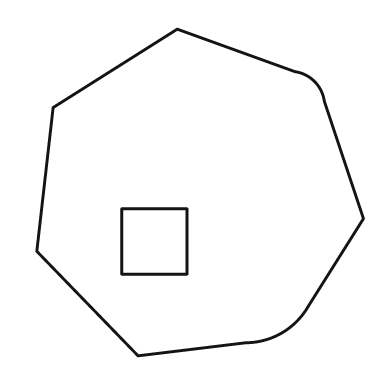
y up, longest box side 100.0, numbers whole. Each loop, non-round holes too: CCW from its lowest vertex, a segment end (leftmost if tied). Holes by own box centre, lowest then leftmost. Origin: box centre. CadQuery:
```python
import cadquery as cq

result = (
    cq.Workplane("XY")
    .moveTo(-19.0, -50.0)
    .lineTo(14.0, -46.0)
    .threePointArc((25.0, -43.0), (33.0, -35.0))
    .lineTo(50.0, -8.0)
    .lineTo(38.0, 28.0)
    .threePointArc((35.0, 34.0), (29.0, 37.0))
    .lineTo(-7.0, 50.0)
    .lineTo(-45.0, 26.0)
    .lineTo(-50.0, -18.0)
    .close()
    .moveTo(-24.0, -25.0)
    .lineTo(-4.0, -25.0)
    .lineTo(-4.0, -5.0)
    .lineTo(-24.0, -5.0)
    .close()
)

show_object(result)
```